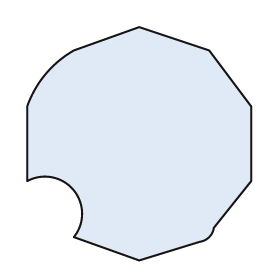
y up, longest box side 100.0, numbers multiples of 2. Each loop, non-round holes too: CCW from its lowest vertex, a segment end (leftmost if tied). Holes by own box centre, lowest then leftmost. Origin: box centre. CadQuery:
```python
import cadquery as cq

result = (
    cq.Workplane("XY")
    .moveTo(0.0, -50.0)
    .lineTo(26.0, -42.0)
    .threePointArc((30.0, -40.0), (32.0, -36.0))
    .lineTo(48.0, -16.0)
    .lineTo(48.0, 16.0)
    .lineTo(30.0, 40.0)
    .lineTo(0.0, 50.0)
    .lineTo(-28.0, 40.0)
    .threePointArc((-40.0, 30.0), (-48.0, 16.0))
    .lineTo(-48.0, -16.0)
    .threePointArc((-28.0, -20.0), (-28.0, -40.0))
    .close()
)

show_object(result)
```